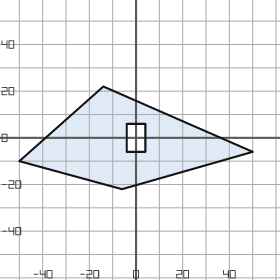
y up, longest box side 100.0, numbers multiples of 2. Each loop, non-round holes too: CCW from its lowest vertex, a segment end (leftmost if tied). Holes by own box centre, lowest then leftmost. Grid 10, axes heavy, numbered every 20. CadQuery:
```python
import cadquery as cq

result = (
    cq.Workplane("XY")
    .moveTo(-6.0, -22.0)
    .lineTo(50.0, -6.0)
    .lineTo(-14.0, 22.0)
    .lineTo(-50.0, -10.0)
    .close()
    .moveTo(-4.0, -6.0)
    .lineTo(4.0, -6.0)
    .lineTo(4.0, 6.0)
    .lineTo(-4.0, 6.0)
    .close()
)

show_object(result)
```